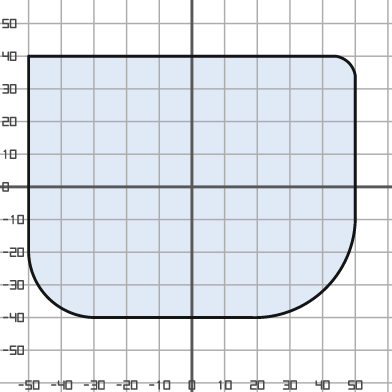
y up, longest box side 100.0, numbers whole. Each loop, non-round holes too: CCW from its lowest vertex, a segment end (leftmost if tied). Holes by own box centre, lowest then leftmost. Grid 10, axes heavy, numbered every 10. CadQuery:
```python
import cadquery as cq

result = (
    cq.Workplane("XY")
    .moveTo(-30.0, -40.0)
    .lineTo(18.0, -40.0)
    .threePointArc((41.0, -31.0), (50.0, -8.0))
    .lineTo(50.0, 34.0)
    .threePointArc((48.0, 38.0), (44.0, 40.0))
    .lineTo(-50.0, 40.0)
    .lineTo(-50.0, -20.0)
    .threePointArc((-44.0, -34.0), (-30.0, -40.0))
    .close()
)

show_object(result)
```